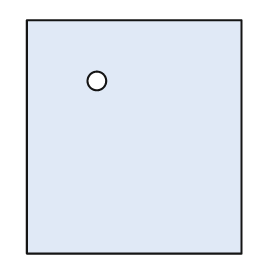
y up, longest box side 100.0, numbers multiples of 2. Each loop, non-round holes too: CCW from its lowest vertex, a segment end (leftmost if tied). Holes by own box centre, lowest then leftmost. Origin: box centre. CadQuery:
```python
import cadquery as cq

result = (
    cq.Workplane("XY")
    .moveTo(-46.0, -50.0)
    .lineTo(46.0, -50.0)
    .lineTo(46.0, 50.0)
    .lineTo(-46.0, 50.0)
    .close()
    .moveTo(-16.0, 24.0)
    .circle(4.0)
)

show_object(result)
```